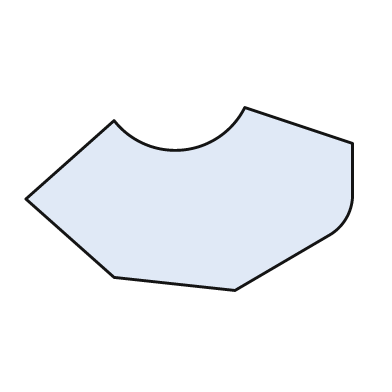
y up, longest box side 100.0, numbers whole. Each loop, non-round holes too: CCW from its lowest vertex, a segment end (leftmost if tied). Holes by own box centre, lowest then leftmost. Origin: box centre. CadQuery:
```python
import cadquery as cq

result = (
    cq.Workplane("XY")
    .moveTo(14.0, -28.0)
    .lineTo(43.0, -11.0)
    .threePointArc((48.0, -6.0), (50.0, 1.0))
    .lineTo(50.0, 17.0)
    .lineTo(17.0, 28.0)
    .threePointArc((-2.0, 15.0), (-23.0, 24.0))
    .lineTo(-50.0, 0.0)
    .lineTo(-23.0, -24.0)
    .close()
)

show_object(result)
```